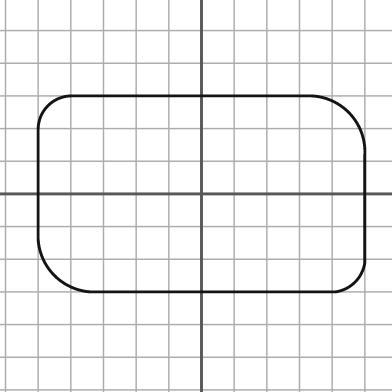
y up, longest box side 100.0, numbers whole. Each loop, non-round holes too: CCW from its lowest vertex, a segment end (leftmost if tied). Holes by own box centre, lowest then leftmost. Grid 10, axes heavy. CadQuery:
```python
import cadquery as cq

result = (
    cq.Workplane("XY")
    .moveTo(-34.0, -30.0)
    .lineTo(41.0, -30.0)
    .threePointArc((47.0, -27.0), (50.0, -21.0))
    .lineTo(50.0, 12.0)
    .threePointArc((45.0, 25.0), (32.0, 30.0))
    .lineTo(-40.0, 30.0)
    .threePointArc((-47.0, 27.0), (-50.0, 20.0))
    .lineTo(-50.0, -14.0)
    .threePointArc((-45.0, -25.0), (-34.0, -30.0))
    .close()
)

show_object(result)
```